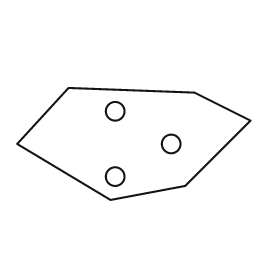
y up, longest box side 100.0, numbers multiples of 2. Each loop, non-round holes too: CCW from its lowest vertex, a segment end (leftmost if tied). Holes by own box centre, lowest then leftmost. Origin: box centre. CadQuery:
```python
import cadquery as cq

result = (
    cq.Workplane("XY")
    .moveTo(-10.0, -24.0)
    .lineTo(22.0, -18.0)
    .lineTo(50.0, 10.0)
    .lineTo(26.0, 22.0)
    .lineTo(-28.0, 24.0)
    .lineTo(-50.0, 0.0)
    .close()
    .moveTo(-8.0, -14.0)
    .circle(4.0)
    .moveTo(16.0, 0.0)
    .circle(4.0)
    .moveTo(-8.0, 14.0)
    .circle(4.0)
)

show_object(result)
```